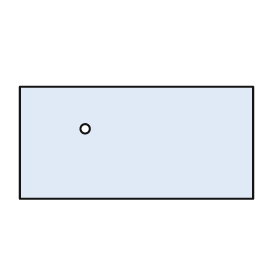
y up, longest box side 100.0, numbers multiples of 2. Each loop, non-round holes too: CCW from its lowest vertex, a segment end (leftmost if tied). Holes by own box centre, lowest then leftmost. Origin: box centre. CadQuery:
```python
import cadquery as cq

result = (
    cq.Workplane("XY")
    .moveTo(-50.0, -24.0)
    .lineTo(50.0, -24.0)
    .lineTo(50.0, 24.0)
    .lineTo(-50.0, 24.0)
    .close()
    .moveTo(-22.0, 6.0)
    .circle(2.0)
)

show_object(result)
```